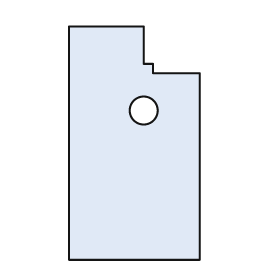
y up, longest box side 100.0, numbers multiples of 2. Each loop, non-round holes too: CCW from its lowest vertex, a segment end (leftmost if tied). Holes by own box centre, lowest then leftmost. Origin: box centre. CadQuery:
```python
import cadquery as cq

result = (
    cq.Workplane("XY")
    .moveTo(-28.0, -50.0)
    .lineTo(28.0, -50.0)
    .lineTo(28.0, 30.0)
    .lineTo(8.0, 30.0)
    .lineTo(8.0, 34.0)
    .lineTo(4.0, 34.0)
    .lineTo(4.0, 50.0)
    .lineTo(-28.0, 50.0)
    .close()
    .moveTo(4.0, 14.0)
    .circle(6.0)
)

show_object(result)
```